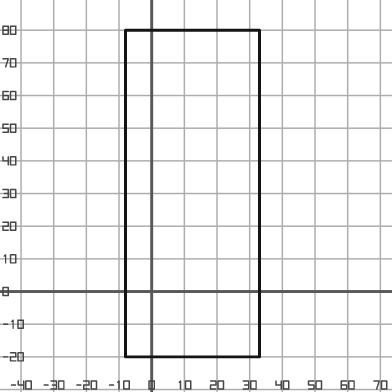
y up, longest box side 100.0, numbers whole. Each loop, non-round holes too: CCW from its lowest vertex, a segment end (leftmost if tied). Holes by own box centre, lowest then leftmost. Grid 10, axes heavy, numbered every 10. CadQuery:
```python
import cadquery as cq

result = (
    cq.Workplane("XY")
    .moveTo(-8.0, -20.0)
    .lineTo(33.0, -20.0)
    .lineTo(33.0, 80.0)
    .lineTo(-8.0, 80.0)
    .close()
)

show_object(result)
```